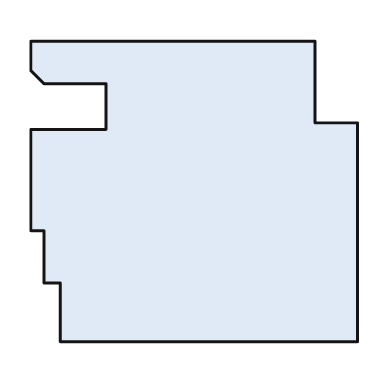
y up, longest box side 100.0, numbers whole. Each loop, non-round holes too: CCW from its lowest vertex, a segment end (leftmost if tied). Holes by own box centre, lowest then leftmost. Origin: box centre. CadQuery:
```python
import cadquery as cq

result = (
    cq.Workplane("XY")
    .moveTo(-41.0, -46.0)
    .lineTo(50.0, -46.0)
    .lineTo(50.0, 21.0)
    .lineTo(37.0, 21.0)
    .lineTo(37.0, 46.0)
    .lineTo(-50.0, 46.0)
    .lineTo(-50.0, 37.0)
    .lineTo(-46.0, 33.0)
    .lineTo(-27.0, 33.0)
    .lineTo(-27.0, 19.0)
    .lineTo(-50.0, 19.0)
    .lineTo(-50.0, -12.0)
    .lineTo(-46.0, -12.0)
    .lineTo(-46.0, -28.0)
    .lineTo(-41.0, -28.0)
    .close()
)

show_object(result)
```